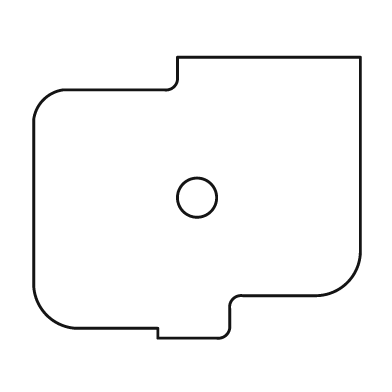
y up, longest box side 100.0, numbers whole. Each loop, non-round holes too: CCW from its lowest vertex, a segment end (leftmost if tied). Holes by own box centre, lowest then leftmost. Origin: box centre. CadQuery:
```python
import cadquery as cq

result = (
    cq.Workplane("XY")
    .moveTo(-12.0, -43.0)
    .lineTo(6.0, -43.0)
    .threePointArc((9.0, -42.0), (10.0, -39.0))
    .lineTo(10.0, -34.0)
    .threePointArc((11.0, -31.0), (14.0, -30.0))
    .lineTo(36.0, -30.0)
    .threePointArc((46.0, -26.0), (50.0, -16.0))
    .lineTo(50.0, 43.0)
    .lineTo(-6.0, 43.0)
    .lineTo(-6.0, 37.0)
    .threePointArc((-7.0, 34.0), (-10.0, 33.0))
    .lineTo(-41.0, 33.0)
    .threePointArc((-47.0, 30.0), (-50.0, 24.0))
    .lineTo(-50.0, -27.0)
    .threePointArc((-46.0, -36.0), (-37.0, -40.0))
    .lineTo(-12.0, -40.0)
    .close()
    .moveTo(0.0, 0.0)
    .circle(6.0)
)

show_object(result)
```